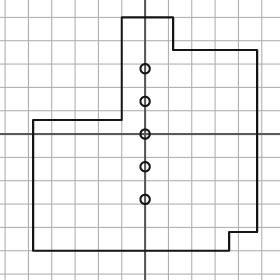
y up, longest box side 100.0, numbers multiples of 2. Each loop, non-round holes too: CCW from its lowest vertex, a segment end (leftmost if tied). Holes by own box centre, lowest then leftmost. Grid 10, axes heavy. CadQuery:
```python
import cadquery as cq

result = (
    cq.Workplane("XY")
    .moveTo(-48.0, -50.0)
    .lineTo(36.0, -50.0)
    .lineTo(36.0, -42.0)
    .lineTo(48.0, -42.0)
    .lineTo(48.0, 36.0)
    .lineTo(12.0, 36.0)
    .lineTo(12.0, 50.0)
    .lineTo(-10.0, 50.0)
    .lineTo(-10.0, 6.0)
    .lineTo(-48.0, 6.0)
    .close()
    .moveTo(0.0, -28.0)
    .circle(2.0)
    .moveTo(0.0, -14.0)
    .circle(2.0)
    .moveTo(0.0, 0.0)
    .circle(2.0)
    .moveTo(0.0, 14.0)
    .circle(2.0)
    .moveTo(0.0, 28.0)
    .circle(2.0)
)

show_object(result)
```